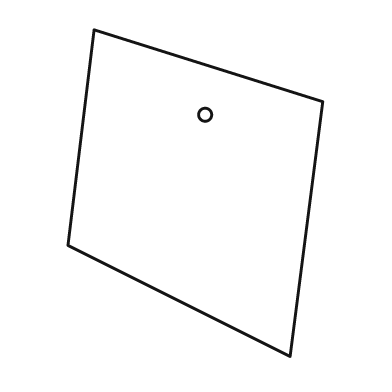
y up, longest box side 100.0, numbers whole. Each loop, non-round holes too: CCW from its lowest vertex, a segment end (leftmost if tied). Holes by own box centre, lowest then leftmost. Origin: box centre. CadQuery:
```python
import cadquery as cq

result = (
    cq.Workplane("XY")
    .moveTo(29.0, -50.0)
    .lineTo(39.0, 28.0)
    .lineTo(-31.0, 50.0)
    .lineTo(-39.0, -16.0)
    .close()
    .moveTo(3.0, 24.0)
    .circle(2.0)
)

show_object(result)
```